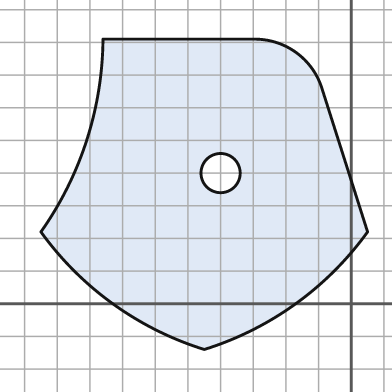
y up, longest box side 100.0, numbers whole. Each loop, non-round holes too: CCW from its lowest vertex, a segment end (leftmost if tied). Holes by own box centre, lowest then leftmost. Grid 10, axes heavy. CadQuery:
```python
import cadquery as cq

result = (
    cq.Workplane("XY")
    .moveTo(-45.0, -14.0)
    .threePointArc((-17.0, 0.0), (5.0, 22.0))
    .lineTo(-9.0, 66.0)
    .threePointArc((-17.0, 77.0), (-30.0, 81.0))
    .lineTo(-76.0, 81.0)
    .threePointArc((-81.0, 50.0), (-95.0, 22.0))
    .threePointArc((-73.0, 0.0), (-45.0, -14.0))
    .close()
    .moveTo(-40.0, 40.0)
    .circle(6.0)
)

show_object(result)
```